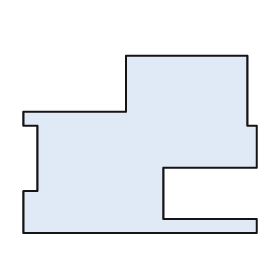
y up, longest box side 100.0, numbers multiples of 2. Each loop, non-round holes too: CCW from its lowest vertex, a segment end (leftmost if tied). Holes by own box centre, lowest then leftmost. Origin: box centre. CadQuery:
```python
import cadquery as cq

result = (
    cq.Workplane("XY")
    .moveTo(-50.0, -38.0)
    .lineTo(50.0, -38.0)
    .lineTo(50.0, -32.0)
    .lineTo(10.0, -32.0)
    .lineTo(10.0, -10.0)
    .lineTo(50.0, -10.0)
    .lineTo(50.0, 8.0)
    .lineTo(46.0, 8.0)
    .lineTo(46.0, 38.0)
    .lineTo(-6.0, 38.0)
    .lineTo(-6.0, 14.0)
    .lineTo(-50.0, 14.0)
    .lineTo(-50.0, 8.0)
    .lineTo(-44.0, 8.0)
    .lineTo(-44.0, -20.0)
    .lineTo(-50.0, -20.0)
    .close()
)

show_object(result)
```